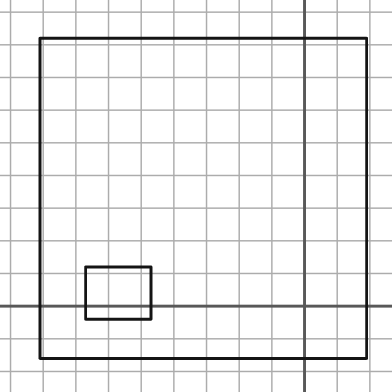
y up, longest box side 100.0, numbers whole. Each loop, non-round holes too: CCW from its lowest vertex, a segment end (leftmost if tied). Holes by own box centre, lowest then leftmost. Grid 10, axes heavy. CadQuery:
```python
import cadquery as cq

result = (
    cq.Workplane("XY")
    .moveTo(-81.0, -16.0)
    .lineTo(19.0, -16.0)
    .lineTo(19.0, 82.0)
    .lineTo(-81.0, 82.0)
    .close()
    .moveTo(-67.0, -4.0)
    .lineTo(-47.0, -4.0)
    .lineTo(-47.0, 12.0)
    .lineTo(-67.0, 12.0)
    .close()
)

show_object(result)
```